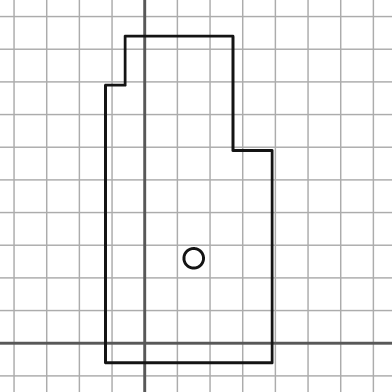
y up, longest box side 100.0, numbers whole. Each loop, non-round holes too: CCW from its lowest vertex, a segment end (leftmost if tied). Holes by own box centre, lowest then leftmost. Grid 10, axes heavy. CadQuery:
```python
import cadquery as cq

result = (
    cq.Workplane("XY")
    .moveTo(-12.0, -6.0)
    .lineTo(39.0, -6.0)
    .lineTo(39.0, 59.0)
    .lineTo(27.0, 59.0)
    .lineTo(27.0, 94.0)
    .lineTo(-6.0, 94.0)
    .lineTo(-6.0, 79.0)
    .lineTo(-12.0, 79.0)
    .close()
    .moveTo(15.0, 26.0)
    .circle(3.0)
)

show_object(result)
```